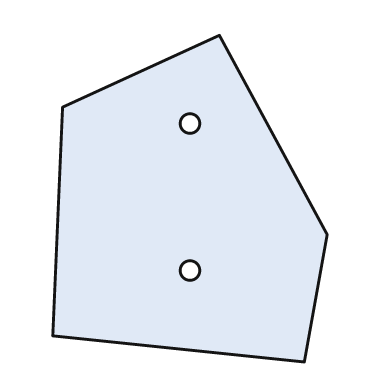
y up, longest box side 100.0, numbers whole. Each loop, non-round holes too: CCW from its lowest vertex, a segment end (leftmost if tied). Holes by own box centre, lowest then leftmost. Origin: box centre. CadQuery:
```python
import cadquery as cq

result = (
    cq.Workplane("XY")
    .moveTo(35.0, -50.0)
    .lineTo(42.0, -11.0)
    .lineTo(9.0, 50.0)
    .lineTo(-39.0, 28.0)
    .lineTo(-42.0, -42.0)
    .close()
    .moveTo(0.0, -22.0)
    .circle(3.0)
    .moveTo(0.0, 23.0)
    .circle(3.0)
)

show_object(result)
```